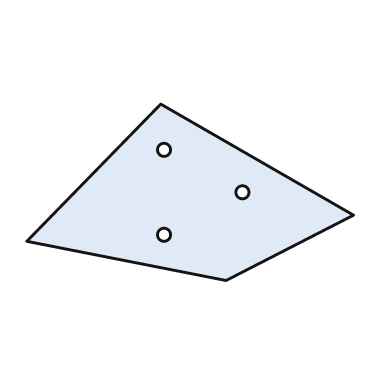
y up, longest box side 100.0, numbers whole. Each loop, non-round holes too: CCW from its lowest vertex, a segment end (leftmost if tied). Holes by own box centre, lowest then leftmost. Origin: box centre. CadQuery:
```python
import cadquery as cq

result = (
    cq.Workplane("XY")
    .moveTo(11.0, -27.0)
    .lineTo(50.0, -7.0)
    .lineTo(-9.0, 27.0)
    .lineTo(-50.0, -15.0)
    .close()
    .moveTo(-8.0, -13.0)
    .circle(2.0)
    .moveTo(16.0, 0.0)
    .circle(2.0)
    .moveTo(-8.0, 13.0)
    .circle(2.0)
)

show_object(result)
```